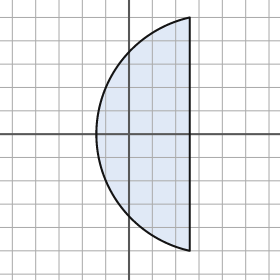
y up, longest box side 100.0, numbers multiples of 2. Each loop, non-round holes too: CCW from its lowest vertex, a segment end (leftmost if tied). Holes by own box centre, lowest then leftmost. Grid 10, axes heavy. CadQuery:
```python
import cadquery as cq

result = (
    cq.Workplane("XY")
    .moveTo(26.0, -50.0)
    .lineTo(26.0, 50.0)
    .threePointArc((-14.0, 0.0), (26.0, -50.0))
    .close()
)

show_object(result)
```